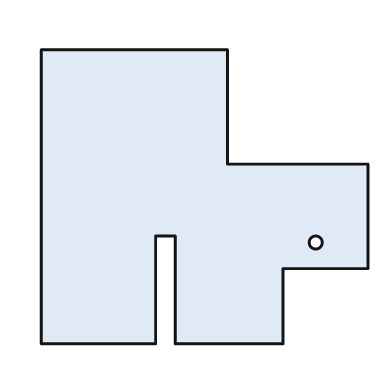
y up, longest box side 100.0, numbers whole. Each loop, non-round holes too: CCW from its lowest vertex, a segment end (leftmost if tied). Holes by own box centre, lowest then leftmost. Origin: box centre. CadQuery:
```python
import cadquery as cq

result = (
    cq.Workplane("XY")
    .moveTo(-50.0, -45.0)
    .lineTo(-15.0, -45.0)
    .lineTo(-15.0, -12.0)
    .lineTo(-9.0, -12.0)
    .lineTo(-9.0, -45.0)
    .lineTo(24.0, -45.0)
    .lineTo(24.0, -22.0)
    .lineTo(50.0, -22.0)
    .lineTo(50.0, 10.0)
    .lineTo(7.0, 10.0)
    .lineTo(7.0, 45.0)
    .lineTo(-50.0, 45.0)
    .close()
    .moveTo(34.0, -14.0)
    .circle(2.0)
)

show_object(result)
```